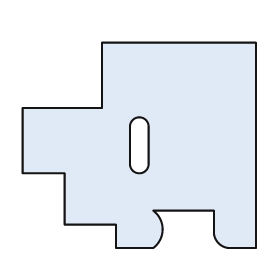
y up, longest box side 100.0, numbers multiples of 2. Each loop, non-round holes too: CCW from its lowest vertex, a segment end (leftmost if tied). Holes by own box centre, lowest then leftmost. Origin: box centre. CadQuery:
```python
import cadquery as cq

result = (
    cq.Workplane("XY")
    .moveTo(-10.0, -44.0)
    .lineTo(6.0, -44.0)
    .threePointArc((10.0, -36.0), (6.0, -28.0))
    .lineTo(32.0, -28.0)
    .lineTo(32.0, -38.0)
    .threePointArc((34.0, -42.0), (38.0, -44.0))
    .lineTo(50.0, -44.0)
    .lineTo(50.0, 44.0)
    .lineTo(-16.0, 44.0)
    .lineTo(-16.0, 16.0)
    .lineTo(-50.0, 16.0)
    .lineTo(-50.0, -12.0)
    .lineTo(-32.0, -12.0)
    .lineTo(-32.0, -34.0)
    .lineTo(-10.0, -34.0)
    .close()
    .moveTo(-4.0, -8.0)
    .threePointArc((0.0, -12.0), (4.0, -8.0))
    .lineTo(4.0, 8.0)
    .threePointArc((0.0, 12.0), (-4.0, 8.0))
    .close()
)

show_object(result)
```